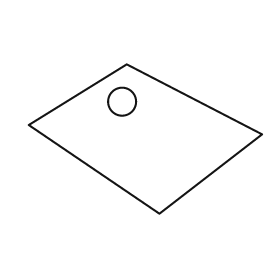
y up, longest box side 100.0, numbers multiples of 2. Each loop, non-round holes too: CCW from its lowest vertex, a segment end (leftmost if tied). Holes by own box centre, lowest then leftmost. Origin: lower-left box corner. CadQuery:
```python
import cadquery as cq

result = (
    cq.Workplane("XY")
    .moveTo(56.0, 0.0)
    .lineTo(100.0, 34.0)
    .lineTo(42.0, 64.0)
    .lineTo(0.0, 38.0)
    .close()
    .moveTo(40.0, 48.0)
    .circle(6.0)
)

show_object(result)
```